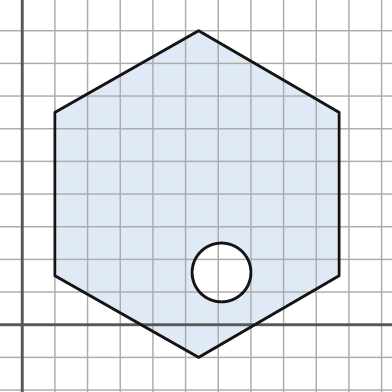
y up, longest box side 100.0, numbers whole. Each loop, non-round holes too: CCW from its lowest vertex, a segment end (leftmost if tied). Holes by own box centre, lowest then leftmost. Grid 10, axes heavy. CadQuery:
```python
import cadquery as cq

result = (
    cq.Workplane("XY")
    .moveTo(54.0, -10.0)
    .lineTo(97.0, 15.0)
    .lineTo(97.0, 65.0)
    .lineTo(54.0, 90.0)
    .lineTo(10.0, 65.0)
    .lineTo(10.0, 15.0)
    .close()
    .moveTo(61.0, 16.0)
    .circle(9.0)
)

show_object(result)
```